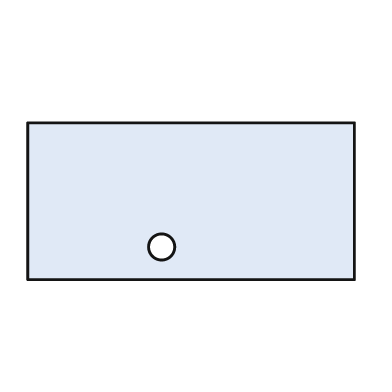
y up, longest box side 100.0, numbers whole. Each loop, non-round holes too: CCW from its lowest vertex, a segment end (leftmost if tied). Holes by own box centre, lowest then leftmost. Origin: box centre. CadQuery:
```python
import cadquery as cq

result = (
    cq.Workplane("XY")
    .moveTo(-50.0, -24.0)
    .lineTo(50.0, -24.0)
    .lineTo(50.0, 24.0)
    .lineTo(-50.0, 24.0)
    .close()
    .moveTo(-9.0, -14.0)
    .circle(4.0)
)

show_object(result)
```